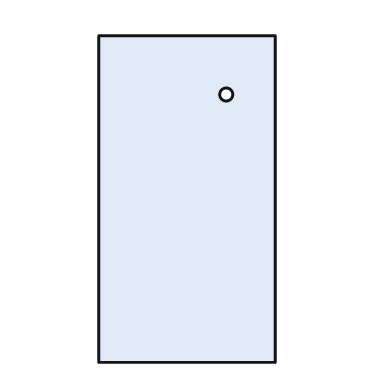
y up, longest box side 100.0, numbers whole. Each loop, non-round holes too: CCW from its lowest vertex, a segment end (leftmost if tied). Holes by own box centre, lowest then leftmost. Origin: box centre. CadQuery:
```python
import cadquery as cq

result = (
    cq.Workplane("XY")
    .moveTo(-27.0, -50.0)
    .lineTo(27.0, -50.0)
    .lineTo(27.0, 50.0)
    .lineTo(-27.0, 50.0)
    .close()
    .moveTo(12.0, 32.0)
    .circle(2.0)
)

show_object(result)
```